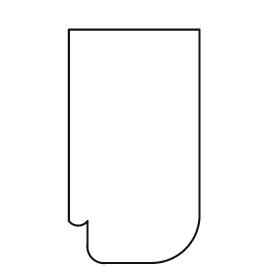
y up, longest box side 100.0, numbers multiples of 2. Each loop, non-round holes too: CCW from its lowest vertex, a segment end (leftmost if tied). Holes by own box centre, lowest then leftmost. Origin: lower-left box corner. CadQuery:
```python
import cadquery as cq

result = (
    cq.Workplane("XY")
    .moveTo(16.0, 0.0)
    .lineTo(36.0, 0.0)
    .threePointArc((50.0, 6.0), (56.0, 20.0))
    .lineTo(56.0, 100.0)
    .lineTo(0.0, 100.0)
    .lineTo(0.0, 18.0)
    .threePointArc((4.0, 16.0), (8.0, 18.0))
    .lineTo(8.0, 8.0)
    .threePointArc((10.0, 2.0), (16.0, 0.0))
    .close()
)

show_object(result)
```